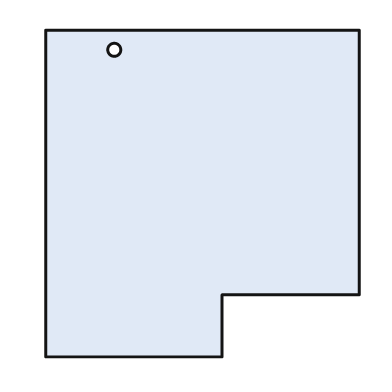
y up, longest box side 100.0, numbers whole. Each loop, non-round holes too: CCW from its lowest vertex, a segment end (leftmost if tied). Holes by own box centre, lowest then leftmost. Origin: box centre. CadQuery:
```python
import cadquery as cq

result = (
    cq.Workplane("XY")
    .moveTo(-48.0, -50.0)
    .lineTo(6.0, -50.0)
    .lineTo(6.0, -31.0)
    .lineTo(48.0, -31.0)
    .lineTo(48.0, 50.0)
    .lineTo(-48.0, 50.0)
    .close()
    .moveTo(-27.0, 44.0)
    .circle(2.0)
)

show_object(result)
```